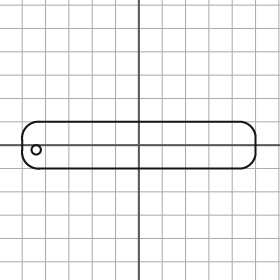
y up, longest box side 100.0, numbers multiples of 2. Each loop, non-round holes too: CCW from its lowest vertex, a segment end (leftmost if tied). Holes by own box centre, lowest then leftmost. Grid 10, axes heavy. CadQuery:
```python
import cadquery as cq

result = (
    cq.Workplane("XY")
    .moveTo(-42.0, -10.0)
    .lineTo(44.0, -10.0)
    .threePointArc((48.0, -8.0), (50.0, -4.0))
    .lineTo(50.0, 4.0)
    .threePointArc((48.0, 8.0), (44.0, 10.0))
    .lineTo(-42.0, 10.0)
    .threePointArc((-48.0, 8.0), (-50.0, 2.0))
    .lineTo(-50.0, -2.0)
    .threePointArc((-48.0, -8.0), (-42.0, -10.0))
    .close()
    .moveTo(-44.0, -2.0)
    .circle(2.0)
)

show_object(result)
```